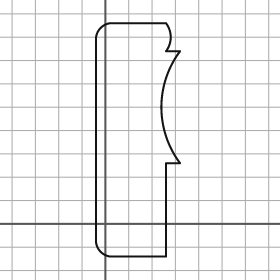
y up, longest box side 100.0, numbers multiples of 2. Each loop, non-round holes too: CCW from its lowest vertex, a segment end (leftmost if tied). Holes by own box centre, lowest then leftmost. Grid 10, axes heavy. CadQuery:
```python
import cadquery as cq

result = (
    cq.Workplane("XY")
    .moveTo(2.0, -14.0)
    .lineTo(26.0, -14.0)
    .lineTo(26.0, 26.0)
    .lineTo(32.0, 26.0)
    .threePointArc((24.0, 50.0), (32.0, 74.0))
    .lineTo(26.0, 74.0)
    .threePointArc((28.0, 80.0), (26.0, 86.0))
    .lineTo(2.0, 86.0)
    .threePointArc((-2.0, 84.0), (-4.0, 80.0))
    .lineTo(-4.0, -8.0)
    .threePointArc((-2.0, -12.0), (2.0, -14.0))
    .close()
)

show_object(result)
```